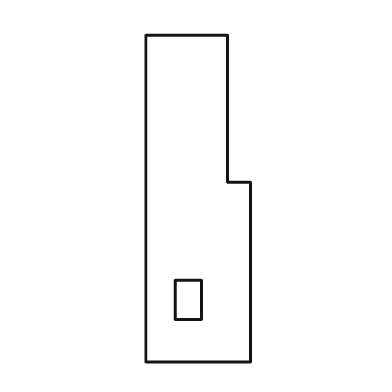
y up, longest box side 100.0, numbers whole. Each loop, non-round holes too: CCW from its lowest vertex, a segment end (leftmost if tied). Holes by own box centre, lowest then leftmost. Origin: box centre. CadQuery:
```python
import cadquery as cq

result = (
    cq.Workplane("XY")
    .moveTo(-16.0, -50.0)
    .lineTo(16.0, -50.0)
    .lineTo(16.0, 5.0)
    .lineTo(9.0, 5.0)
    .lineTo(9.0, 50.0)
    .lineTo(-16.0, 50.0)
    .close()
    .moveTo(-7.0, -37.0)
    .lineTo(1.0, -37.0)
    .lineTo(1.0, -25.0)
    .lineTo(-7.0, -25.0)
    .close()
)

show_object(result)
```